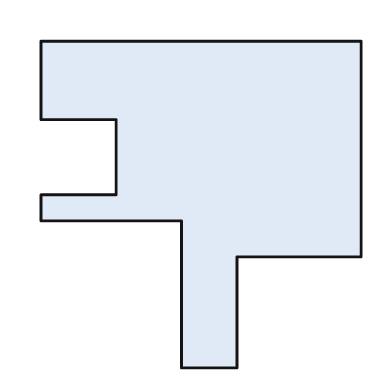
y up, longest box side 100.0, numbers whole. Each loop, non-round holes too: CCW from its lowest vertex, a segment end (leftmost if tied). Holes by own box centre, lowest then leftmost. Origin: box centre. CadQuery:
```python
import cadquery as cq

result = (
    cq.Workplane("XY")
    .moveTo(-6.0, -50.0)
    .lineTo(11.0, -50.0)
    .lineTo(11.0, -16.0)
    .lineTo(49.0, -16.0)
    .lineTo(49.0, 50.0)
    .lineTo(-49.0, 50.0)
    .lineTo(-49.0, 26.0)
    .lineTo(-26.0, 26.0)
    .lineTo(-26.0, 3.0)
    .lineTo(-49.0, 3.0)
    .lineTo(-49.0, -5.0)
    .lineTo(-6.0, -5.0)
    .close()
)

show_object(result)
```